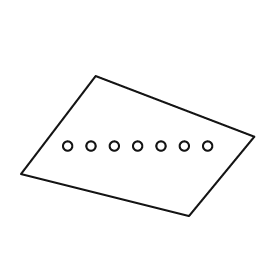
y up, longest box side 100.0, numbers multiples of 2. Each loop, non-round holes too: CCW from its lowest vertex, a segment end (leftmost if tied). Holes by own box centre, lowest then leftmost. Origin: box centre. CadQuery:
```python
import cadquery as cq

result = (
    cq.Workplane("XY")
    .moveTo(22.0, -30.0)
    .lineTo(50.0, 4.0)
    .lineTo(-18.0, 30.0)
    .lineTo(-50.0, -12.0)
    .close()
    .moveTo(-30.0, 0.0)
    .circle(2.0)
    .moveTo(-20.0, 0.0)
    .circle(2.0)
    .moveTo(-10.0, 0.0)
    .circle(2.0)
    .moveTo(0.0, 0.0)
    .circle(2.0)
    .moveTo(10.0, 0.0)
    .circle(2.0)
    .moveTo(20.0, 0.0)
    .circle(2.0)
    .moveTo(30.0, 0.0)
    .circle(2.0)
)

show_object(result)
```